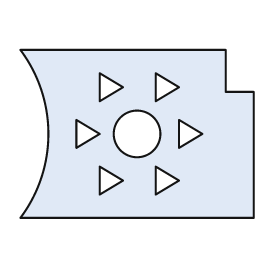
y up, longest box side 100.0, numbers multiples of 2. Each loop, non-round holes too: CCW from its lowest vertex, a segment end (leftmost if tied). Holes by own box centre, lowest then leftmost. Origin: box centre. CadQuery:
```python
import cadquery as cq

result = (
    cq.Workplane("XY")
    .moveTo(-50.0, -36.0)
    .lineTo(50.0, -36.0)
    .lineTo(50.0, 18.0)
    .lineTo(38.0, 18.0)
    .lineTo(38.0, 36.0)
    .lineTo(-50.0, 36.0)
    .threePointArc((-38.0, 0.0), (-50.0, -36.0))
    .close()
    .moveTo(-16.0, -26.0)
    .lineTo(-6.0, -20.0)
    .lineTo(-16.0, -14.0)
    .close()
    .moveTo(8.0, -26.0)
    .lineTo(18.0, -20.0)
    .lineTo(8.0, -14.0)
    .close()
    .moveTo(-26.0, -6.0)
    .lineTo(-16.0, 0.0)
    .lineTo(-26.0, 6.0)
    .close()
    .moveTo(0.0, 0.0)
    .circle(10.0)
    .moveTo(18.0, -6.0)
    .lineTo(28.0, 0.0)
    .lineTo(18.0, 6.0)
    .close()
    .moveTo(-16.0, 14.0)
    .lineTo(-6.0, 20.0)
    .lineTo(-16.0, 26.0)
    .close()
    .moveTo(8.0, 14.0)
    .lineTo(18.0, 20.0)
    .lineTo(8.0, 26.0)
    .close()
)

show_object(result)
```